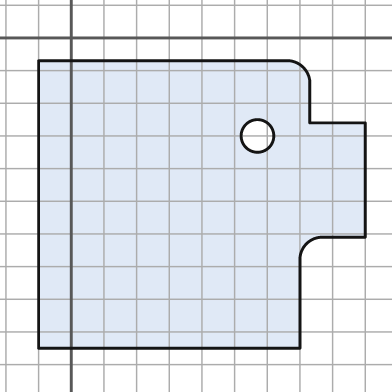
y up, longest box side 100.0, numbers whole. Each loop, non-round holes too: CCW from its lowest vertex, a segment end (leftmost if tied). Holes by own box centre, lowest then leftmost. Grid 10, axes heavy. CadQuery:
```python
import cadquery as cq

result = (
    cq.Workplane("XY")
    .moveTo(-10.0, -95.0)
    .lineTo(70.0, -95.0)
    .lineTo(70.0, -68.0)
    .threePointArc((72.0, -63.0), (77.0, -61.0))
    .lineTo(90.0, -61.0)
    .lineTo(90.0, -26.0)
    .lineTo(73.0, -26.0)
    .lineTo(73.0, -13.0)
    .threePointArc((71.0, -9.0), (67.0, -7.0))
    .lineTo(-10.0, -7.0)
    .close()
    .moveTo(57.0, -30.0)
    .circle(5.0)
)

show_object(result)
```